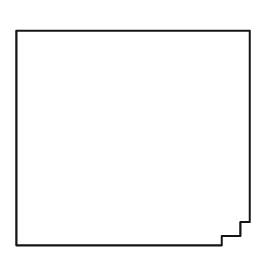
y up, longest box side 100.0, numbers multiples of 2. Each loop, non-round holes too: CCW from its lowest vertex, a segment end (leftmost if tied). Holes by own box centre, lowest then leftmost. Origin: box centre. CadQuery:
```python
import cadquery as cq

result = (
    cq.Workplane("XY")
    .moveTo(-50.0, -46.0)
    .lineTo(38.0, -46.0)
    .lineTo(38.0, -42.0)
    .lineTo(46.0, -42.0)
    .lineTo(46.0, -36.0)
    .lineTo(50.0, -36.0)
    .lineTo(50.0, 46.0)
    .lineTo(-50.0, 46.0)
    .close()
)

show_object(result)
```